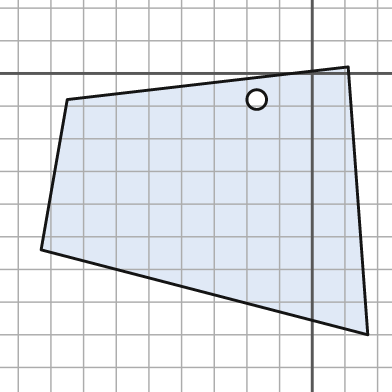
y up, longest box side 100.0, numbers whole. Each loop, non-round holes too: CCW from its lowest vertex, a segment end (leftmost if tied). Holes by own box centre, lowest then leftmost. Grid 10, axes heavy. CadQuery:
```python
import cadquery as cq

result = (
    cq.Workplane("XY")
    .moveTo(17.0, -80.0)
    .lineTo(11.0, 2.0)
    .lineTo(-75.0, -8.0)
    .lineTo(-83.0, -54.0)
    .close()
    .moveTo(-17.0, -8.0)
    .circle(3.0)
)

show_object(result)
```